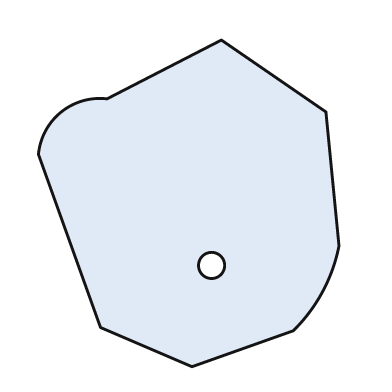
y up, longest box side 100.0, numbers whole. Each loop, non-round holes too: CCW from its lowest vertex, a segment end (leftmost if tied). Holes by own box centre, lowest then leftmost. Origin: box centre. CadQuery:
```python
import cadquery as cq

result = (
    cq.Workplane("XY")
    .moveTo(1.0, -50.0)
    .lineTo(32.0, -39.0)
    .threePointArc((41.0, -27.0), (46.0, -13.0))
    .lineTo(42.0, 28.0)
    .lineTo(10.0, 50.0)
    .lineTo(-25.0, 32.0)
    .threePointArc((-39.0, 28.0), (-46.0, 15.0))
    .lineTo(-27.0, -38.0)
    .close()
    .moveTo(7.0, -19.0)
    .circle(4.0)
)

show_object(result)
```